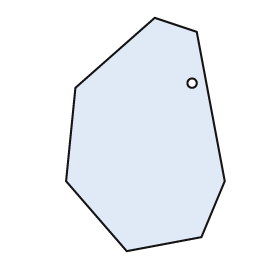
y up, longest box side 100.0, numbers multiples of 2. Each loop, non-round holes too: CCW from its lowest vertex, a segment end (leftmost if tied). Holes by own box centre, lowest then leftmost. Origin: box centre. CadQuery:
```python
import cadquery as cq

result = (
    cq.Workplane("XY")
    .moveTo(-8.0, -50.0)
    .lineTo(24.0, -44.0)
    .lineTo(34.0, -20.0)
    .lineTo(22.0, 44.0)
    .lineTo(4.0, 50.0)
    .lineTo(-30.0, 20.0)
    .lineTo(-34.0, -20.0)
    .close()
    .moveTo(20.0, 22.0)
    .circle(2.0)
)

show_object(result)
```